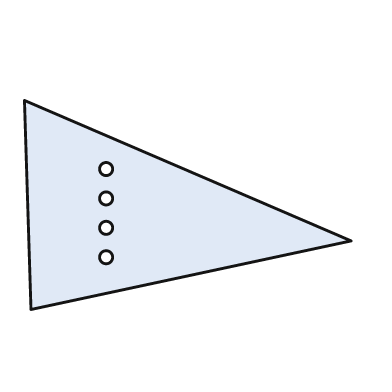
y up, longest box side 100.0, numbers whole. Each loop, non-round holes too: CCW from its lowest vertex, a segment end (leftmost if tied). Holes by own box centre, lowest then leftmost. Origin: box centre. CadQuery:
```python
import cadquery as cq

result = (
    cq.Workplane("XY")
    .moveTo(-48.0, -32.0)
    .lineTo(50.0, -11.0)
    .lineTo(-50.0, 32.0)
    .close()
    .moveTo(-25.0, -16.0)
    .circle(2.0)
    .moveTo(-25.0, -7.0)
    .circle(2.0)
    .moveTo(-25.0, 2.0)
    .circle(2.0)
    .moveTo(-25.0, 11.0)
    .circle(2.0)
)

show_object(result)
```